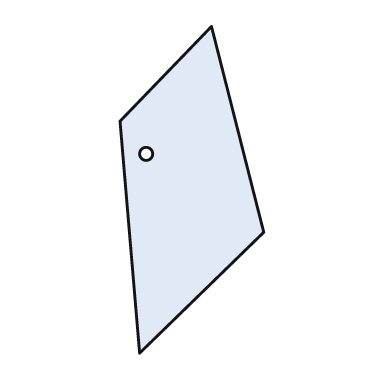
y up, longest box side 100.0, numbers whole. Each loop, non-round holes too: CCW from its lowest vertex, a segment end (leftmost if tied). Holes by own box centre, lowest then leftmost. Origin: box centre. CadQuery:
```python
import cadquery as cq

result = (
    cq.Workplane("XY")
    .moveTo(-16.0, -50.0)
    .lineTo(22.0, -13.0)
    .lineTo(6.0, 50.0)
    .lineTo(-22.0, 21.0)
    .close()
    .moveTo(-14.0, 11.0)
    .circle(2.0)
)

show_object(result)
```